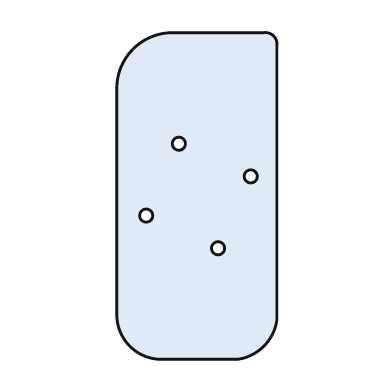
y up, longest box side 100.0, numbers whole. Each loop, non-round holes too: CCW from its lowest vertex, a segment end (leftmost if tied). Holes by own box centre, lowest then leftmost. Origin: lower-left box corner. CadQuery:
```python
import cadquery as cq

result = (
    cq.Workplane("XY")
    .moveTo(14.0, 0.0)
    .lineTo(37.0, 0.0)
    .threePointArc((45.0, 4.0), (49.0, 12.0))
    .lineTo(49.0, 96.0)
    .threePointArc((48.0, 99.0), (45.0, 100.0))
    .lineTo(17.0, 100.0)
    .threePointArc((5.0, 95.0), (0.0, 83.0))
    .lineTo(0.0, 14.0)
    .threePointArc((4.0, 4.0), (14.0, 0.0))
    .close()
    .moveTo(31.0, 34.0)
    .circle(2.0)
    .moveTo(9.0, 44.0)
    .circle(2.0)
    .moveTo(41.0, 56.0)
    .circle(2.0)
    .moveTo(19.0, 66.0)
    .circle(2.0)
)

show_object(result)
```